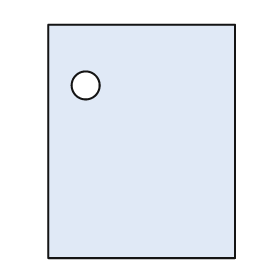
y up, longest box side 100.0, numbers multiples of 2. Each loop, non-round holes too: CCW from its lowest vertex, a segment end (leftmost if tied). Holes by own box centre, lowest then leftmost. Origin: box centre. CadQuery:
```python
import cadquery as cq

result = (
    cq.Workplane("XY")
    .moveTo(-40.0, -50.0)
    .lineTo(40.0, -50.0)
    .lineTo(40.0, 50.0)
    .lineTo(-40.0, 50.0)
    .close()
    .moveTo(-24.0, 24.0)
    .circle(6.0)
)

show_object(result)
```